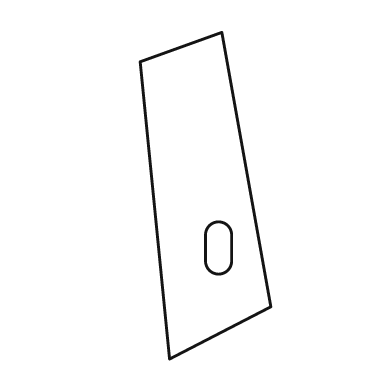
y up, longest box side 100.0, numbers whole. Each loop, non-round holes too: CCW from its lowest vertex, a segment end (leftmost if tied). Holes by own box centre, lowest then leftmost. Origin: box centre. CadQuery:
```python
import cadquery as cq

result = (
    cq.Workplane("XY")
    .moveTo(-11.0, -50.0)
    .lineTo(20.0, -34.0)
    .lineTo(5.0, 50.0)
    .lineTo(-20.0, 41.0)
    .close()
    .moveTo(0.0, -20.0)
    .threePointArc((4.0, -24.0), (8.0, -20.0))
    .lineTo(8.0, -12.0)
    .threePointArc((4.0, -8.0), (0.0, -12.0))
    .close()
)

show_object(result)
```